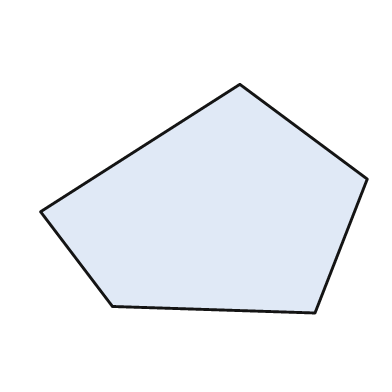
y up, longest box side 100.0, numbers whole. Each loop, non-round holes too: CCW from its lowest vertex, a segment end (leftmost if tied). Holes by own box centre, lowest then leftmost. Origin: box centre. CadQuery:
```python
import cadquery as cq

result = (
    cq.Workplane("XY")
    .moveTo(34.0, -35.0)
    .lineTo(50.0, 6.0)
    .lineTo(11.0, 35.0)
    .lineTo(-50.0, -4.0)
    .lineTo(-28.0, -33.0)
    .close()
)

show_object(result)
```